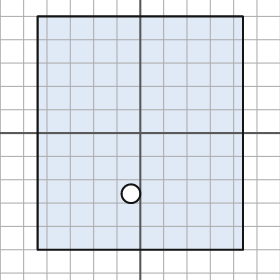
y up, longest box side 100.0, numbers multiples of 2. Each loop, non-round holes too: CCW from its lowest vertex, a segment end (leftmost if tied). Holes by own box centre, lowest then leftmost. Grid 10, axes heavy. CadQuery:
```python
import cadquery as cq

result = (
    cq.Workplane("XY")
    .moveTo(-44.0, -50.0)
    .lineTo(44.0, -50.0)
    .lineTo(44.0, 50.0)
    .lineTo(-44.0, 50.0)
    .close()
    .moveTo(-4.0, -26.0)
    .circle(4.0)
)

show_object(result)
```